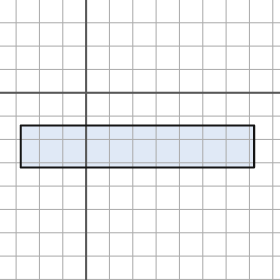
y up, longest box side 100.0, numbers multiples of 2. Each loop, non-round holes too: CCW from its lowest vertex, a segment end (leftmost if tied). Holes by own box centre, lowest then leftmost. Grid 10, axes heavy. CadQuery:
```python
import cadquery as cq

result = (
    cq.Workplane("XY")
    .moveTo(-28.0, -32.0)
    .lineTo(72.0, -32.0)
    .lineTo(72.0, -14.0)
    .lineTo(-28.0, -14.0)
    .close()
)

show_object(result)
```